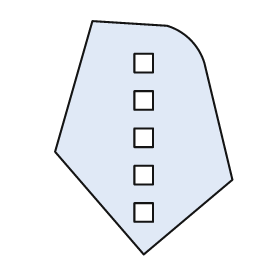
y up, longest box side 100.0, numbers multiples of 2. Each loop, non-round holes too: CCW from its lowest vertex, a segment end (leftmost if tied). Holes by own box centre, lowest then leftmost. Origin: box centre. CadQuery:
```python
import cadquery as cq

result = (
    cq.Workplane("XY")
    .moveTo(0.0, -50.0)
    .lineTo(38.0, -18.0)
    .lineTo(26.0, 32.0)
    .threePointArc((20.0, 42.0), (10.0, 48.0))
    .lineTo(-22.0, 50.0)
    .lineTo(-38.0, -6.0)
    .close()
    .moveTo(-4.0, -36.0)
    .lineTo(4.0, -36.0)
    .lineTo(4.0, -28.0)
    .lineTo(-4.0, -28.0)
    .close()
    .moveTo(-4.0, -20.0)
    .lineTo(4.0, -20.0)
    .lineTo(4.0, -12.0)
    .lineTo(-4.0, -12.0)
    .close()
    .moveTo(-4.0, -4.0)
    .lineTo(4.0, -4.0)
    .lineTo(4.0, 4.0)
    .lineTo(-4.0, 4.0)
    .close()
    .moveTo(-4.0, 12.0)
    .lineTo(4.0, 12.0)
    .lineTo(4.0, 20.0)
    .lineTo(-4.0, 20.0)
    .close()
    .moveTo(-4.0, 28.0)
    .lineTo(4.0, 28.0)
    .lineTo(4.0, 36.0)
    .lineTo(-4.0, 36.0)
    .close()
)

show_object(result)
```